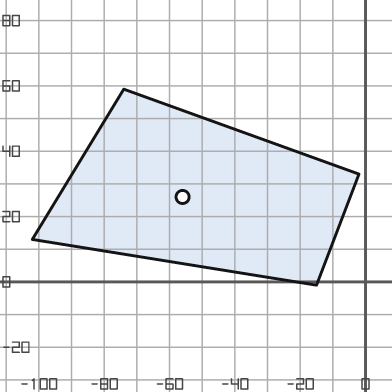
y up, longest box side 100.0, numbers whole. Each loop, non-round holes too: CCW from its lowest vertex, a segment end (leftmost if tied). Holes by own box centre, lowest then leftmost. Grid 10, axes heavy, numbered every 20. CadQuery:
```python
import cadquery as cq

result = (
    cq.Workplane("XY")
    .moveTo(-15.0, -1.0)
    .lineTo(-2.0, 33.0)
    .lineTo(-74.0, 59.0)
    .lineTo(-102.0, 13.0)
    .close()
    .moveTo(-56.0, 26.0)
    .circle(2.0)
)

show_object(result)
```